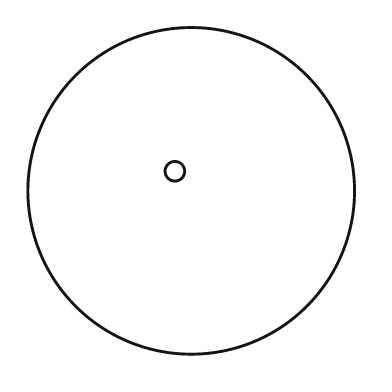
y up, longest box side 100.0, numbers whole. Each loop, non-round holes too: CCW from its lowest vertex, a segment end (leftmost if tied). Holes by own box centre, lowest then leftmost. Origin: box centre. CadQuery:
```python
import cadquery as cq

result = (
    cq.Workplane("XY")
    .moveTo(0.0, 0.0)
    .circle(50.0)
    .moveTo(-5.0, 6.0)
    .circle(3.0)
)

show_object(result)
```